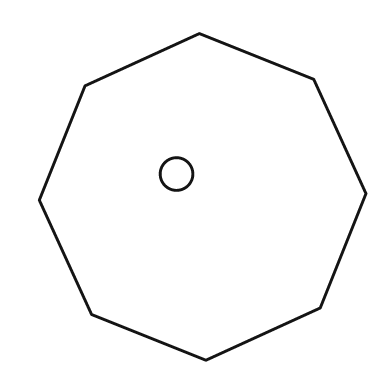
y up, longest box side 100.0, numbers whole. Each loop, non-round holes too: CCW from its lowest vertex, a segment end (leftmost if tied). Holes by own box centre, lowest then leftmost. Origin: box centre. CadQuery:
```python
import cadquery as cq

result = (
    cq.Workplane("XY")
    .moveTo(1.0, -50.0)
    .lineTo(36.0, -34.0)
    .lineTo(50.0, 1.0)
    .lineTo(34.0, 36.0)
    .lineTo(-1.0, 50.0)
    .lineTo(-36.0, 34.0)
    .lineTo(-50.0, -1.0)
    .lineTo(-34.0, -36.0)
    .close()
    .moveTo(-8.0, 7.0)
    .circle(5.0)
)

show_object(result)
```